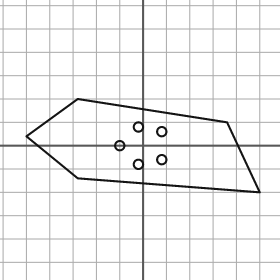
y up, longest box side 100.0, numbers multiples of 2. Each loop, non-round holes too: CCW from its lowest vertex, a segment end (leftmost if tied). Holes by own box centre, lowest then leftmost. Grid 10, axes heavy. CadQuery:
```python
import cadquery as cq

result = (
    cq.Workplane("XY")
    .moveTo(50.0, -20.0)
    .lineTo(36.0, 10.0)
    .lineTo(-28.0, 20.0)
    .lineTo(-50.0, 4.0)
    .lineTo(-28.0, -14.0)
    .close()
    .moveTo(-2.0, -8.0)
    .circle(2.0)
    .moveTo(8.0, -6.0)
    .circle(2.0)
    .moveTo(-10.0, 0.0)
    .circle(2.0)
    .moveTo(8.0, 6.0)
    .circle(2.0)
    .moveTo(-2.0, 8.0)
    .circle(2.0)
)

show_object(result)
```